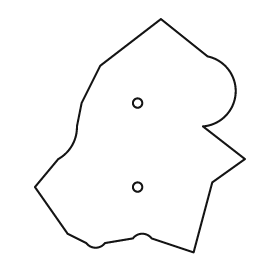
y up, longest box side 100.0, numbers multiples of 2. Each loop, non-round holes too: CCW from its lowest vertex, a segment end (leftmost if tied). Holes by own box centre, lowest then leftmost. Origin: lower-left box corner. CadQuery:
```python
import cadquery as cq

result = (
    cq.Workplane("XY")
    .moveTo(68.0, 0.0)
    .lineTo(76.0, 30.0)
    .lineTo(90.0, 40.0)
    .lineTo(72.0, 54.0)
    .threePointArc((86.0, 68.0), (74.0, 84.0))
    .lineTo(54.0, 100.0)
    .lineTo(28.0, 80.0)
    .lineTo(20.0, 64.0)
    .lineTo(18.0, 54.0)
    .threePointArc((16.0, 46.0), (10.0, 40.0))
    .lineTo(0.0, 28.0)
    .lineTo(14.0, 8.0)
    .lineTo(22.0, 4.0)
    .threePointArc((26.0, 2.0), (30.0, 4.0))
    .lineTo(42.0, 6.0)
    .threePointArc((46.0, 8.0), (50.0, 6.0))
    .close()
    .moveTo(44.0, 28.0)
    .circle(2.0)
    .moveTo(44.0, 64.0)
    .circle(2.0)
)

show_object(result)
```